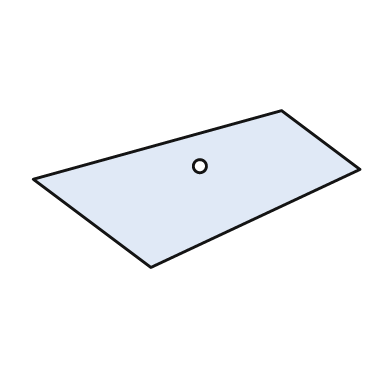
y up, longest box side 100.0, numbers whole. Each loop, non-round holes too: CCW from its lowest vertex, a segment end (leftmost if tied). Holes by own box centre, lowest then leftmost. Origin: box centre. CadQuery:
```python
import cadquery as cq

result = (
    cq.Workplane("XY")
    .moveTo(-14.0, -24.0)
    .lineTo(50.0, 6.0)
    .lineTo(26.0, 24.0)
    .lineTo(-50.0, 3.0)
    .close()
    .moveTo(1.0, 7.0)
    .circle(2.0)
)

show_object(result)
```